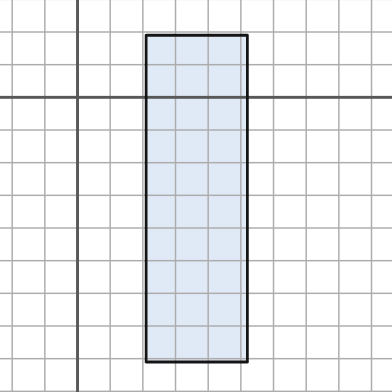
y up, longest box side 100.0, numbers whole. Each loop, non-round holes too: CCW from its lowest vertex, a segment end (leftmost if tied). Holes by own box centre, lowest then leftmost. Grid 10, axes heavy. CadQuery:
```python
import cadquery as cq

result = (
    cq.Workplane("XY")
    .moveTo(21.0, -81.0)
    .lineTo(52.0, -81.0)
    .lineTo(52.0, 19.0)
    .lineTo(21.0, 19.0)
    .close()
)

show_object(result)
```